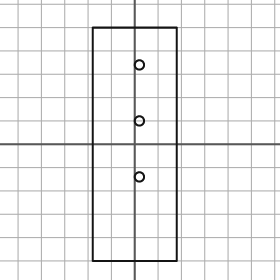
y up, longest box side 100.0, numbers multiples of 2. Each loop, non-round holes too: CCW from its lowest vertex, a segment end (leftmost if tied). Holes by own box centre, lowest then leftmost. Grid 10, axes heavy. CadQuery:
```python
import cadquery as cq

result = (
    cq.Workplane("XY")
    .moveTo(-18.0, -50.0)
    .lineTo(18.0, -50.0)
    .lineTo(18.0, 50.0)
    .lineTo(-18.0, 50.0)
    .close()
    .moveTo(2.0, -14.0)
    .circle(2.0)
    .moveTo(2.0, 10.0)
    .circle(2.0)
    .moveTo(2.0, 34.0)
    .circle(2.0)
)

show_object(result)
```